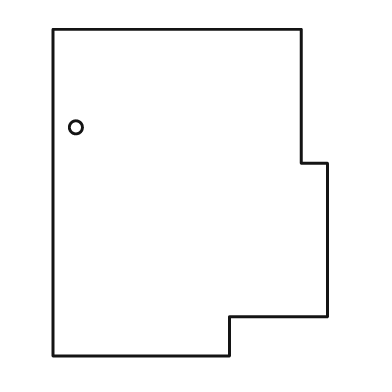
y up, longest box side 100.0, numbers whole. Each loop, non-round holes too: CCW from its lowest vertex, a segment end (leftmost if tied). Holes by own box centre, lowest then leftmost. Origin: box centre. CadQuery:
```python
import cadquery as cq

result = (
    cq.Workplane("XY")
    .moveTo(-42.0, -50.0)
    .lineTo(12.0, -50.0)
    .lineTo(12.0, -38.0)
    .lineTo(42.0, -38.0)
    .lineTo(42.0, 9.0)
    .lineTo(34.0, 9.0)
    .lineTo(34.0, 50.0)
    .lineTo(-42.0, 50.0)
    .close()
    .moveTo(-35.0, 20.0)
    .circle(2.0)
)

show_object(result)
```